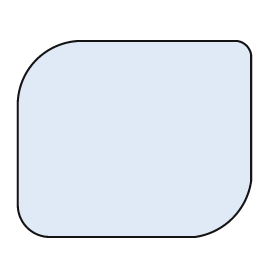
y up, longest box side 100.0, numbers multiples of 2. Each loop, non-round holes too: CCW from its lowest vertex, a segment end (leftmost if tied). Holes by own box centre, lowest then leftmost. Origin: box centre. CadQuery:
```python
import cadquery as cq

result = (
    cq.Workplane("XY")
    .moveTo(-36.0, -42.0)
    .lineTo(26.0, -42.0)
    .threePointArc((42.0, -34.0), (50.0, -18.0))
    .lineTo(50.0, 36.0)
    .threePointArc((48.0, 40.0), (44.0, 42.0))
    .lineTo(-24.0, 42.0)
    .threePointArc((-42.0, 34.0), (-50.0, 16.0))
    .lineTo(-50.0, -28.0)
    .threePointArc((-46.0, -38.0), (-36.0, -42.0))
    .close()
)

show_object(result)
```